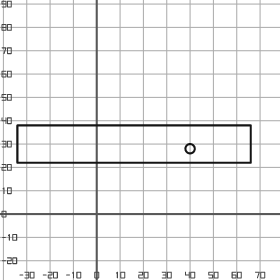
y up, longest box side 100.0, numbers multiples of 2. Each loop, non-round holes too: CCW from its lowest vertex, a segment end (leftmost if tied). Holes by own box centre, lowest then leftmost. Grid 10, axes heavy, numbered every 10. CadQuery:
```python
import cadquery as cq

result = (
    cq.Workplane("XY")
    .moveTo(-34.0, 22.0)
    .lineTo(66.0, 22.0)
    .lineTo(66.0, 38.0)
    .lineTo(-34.0, 38.0)
    .close()
    .moveTo(40.0, 28.0)
    .circle(2.0)
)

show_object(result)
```